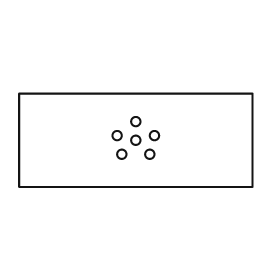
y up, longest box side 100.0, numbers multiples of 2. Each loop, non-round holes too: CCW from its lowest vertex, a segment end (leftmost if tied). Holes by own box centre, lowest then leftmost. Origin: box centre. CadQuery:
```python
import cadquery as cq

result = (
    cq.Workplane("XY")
    .moveTo(-50.0, -20.0)
    .lineTo(50.0, -20.0)
    .lineTo(50.0, 20.0)
    .lineTo(-50.0, 20.0)
    .close()
    .moveTo(-6.0, -6.0)
    .circle(2.0)
    .moveTo(6.0, -6.0)
    .circle(2.0)
    .moveTo(0.0, 0.0)
    .circle(2.0)
    .moveTo(-8.0, 2.0)
    .circle(2.0)
    .moveTo(8.0, 2.0)
    .circle(2.0)
    .moveTo(0.0, 8.0)
    .circle(2.0)
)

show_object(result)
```